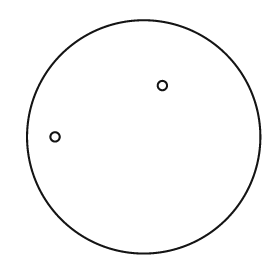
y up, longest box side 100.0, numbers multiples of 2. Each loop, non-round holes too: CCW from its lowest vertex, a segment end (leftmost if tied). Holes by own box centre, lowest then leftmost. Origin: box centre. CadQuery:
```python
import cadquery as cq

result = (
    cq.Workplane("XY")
    .moveTo(0.0, 0.0)
    .circle(50.0)
    .moveTo(-38.0, 0.0)
    .circle(2.0)
    .moveTo(8.0, 22.0)
    .circle(2.0)
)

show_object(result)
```